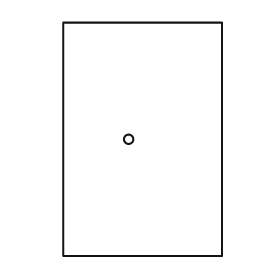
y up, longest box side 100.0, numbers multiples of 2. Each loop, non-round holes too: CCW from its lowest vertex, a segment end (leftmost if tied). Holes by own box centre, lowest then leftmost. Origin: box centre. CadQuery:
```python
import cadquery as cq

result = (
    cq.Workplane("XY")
    .moveTo(-34.0, -50.0)
    .lineTo(34.0, -50.0)
    .lineTo(34.0, 50.0)
    .lineTo(-34.0, 50.0)
    .close()
    .moveTo(-6.0, 0.0)
    .circle(2.0)
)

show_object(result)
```